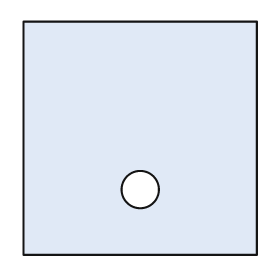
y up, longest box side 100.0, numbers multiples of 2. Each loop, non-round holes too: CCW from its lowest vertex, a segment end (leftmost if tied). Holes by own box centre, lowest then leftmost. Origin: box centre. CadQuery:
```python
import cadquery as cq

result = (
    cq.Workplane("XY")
    .moveTo(-50.0, -50.0)
    .lineTo(50.0, -50.0)
    .lineTo(50.0, 50.0)
    .lineTo(-50.0, 50.0)
    .close()
    .moveTo(0.0, -22.0)
    .circle(8.0)
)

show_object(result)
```